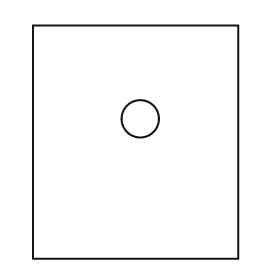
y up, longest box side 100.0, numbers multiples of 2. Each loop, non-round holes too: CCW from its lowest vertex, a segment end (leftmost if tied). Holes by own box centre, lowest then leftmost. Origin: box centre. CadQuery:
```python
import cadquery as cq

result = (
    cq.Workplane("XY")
    .moveTo(-44.0, -50.0)
    .lineTo(44.0, -50.0)
    .lineTo(44.0, 50.0)
    .lineTo(-44.0, 50.0)
    .close()
    .moveTo(2.0, 10.0)
    .circle(8.0)
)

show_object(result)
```